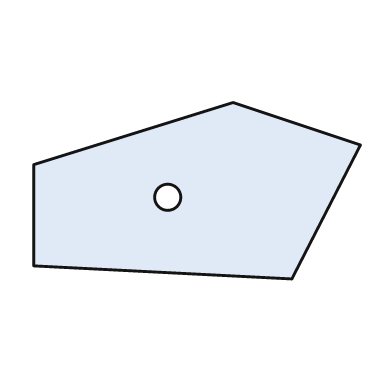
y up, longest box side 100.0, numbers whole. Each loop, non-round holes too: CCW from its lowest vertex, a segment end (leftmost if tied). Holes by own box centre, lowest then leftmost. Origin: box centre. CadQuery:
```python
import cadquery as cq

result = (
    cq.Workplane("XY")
    .moveTo(29.0, -27.0)
    .lineTo(50.0, 14.0)
    .lineTo(11.0, 27.0)
    .lineTo(-50.0, 8.0)
    .lineTo(-50.0, -23.0)
    .close()
    .moveTo(-9.0, -2.0)
    .circle(4.0)
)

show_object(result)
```